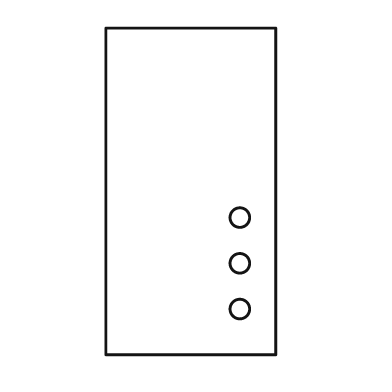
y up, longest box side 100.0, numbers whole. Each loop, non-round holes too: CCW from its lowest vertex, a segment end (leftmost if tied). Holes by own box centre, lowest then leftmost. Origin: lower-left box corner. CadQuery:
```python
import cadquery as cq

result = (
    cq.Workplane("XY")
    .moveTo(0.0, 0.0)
    .lineTo(52.0, 0.0)
    .lineTo(52.0, 100.0)
    .lineTo(0.0, 100.0)
    .close()
    .moveTo(41.0, 14.0)
    .circle(3.0)
    .moveTo(41.0, 28.0)
    .circle(3.0)
    .moveTo(41.0, 42.0)
    .circle(3.0)
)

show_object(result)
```